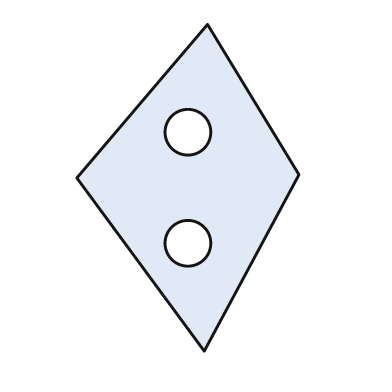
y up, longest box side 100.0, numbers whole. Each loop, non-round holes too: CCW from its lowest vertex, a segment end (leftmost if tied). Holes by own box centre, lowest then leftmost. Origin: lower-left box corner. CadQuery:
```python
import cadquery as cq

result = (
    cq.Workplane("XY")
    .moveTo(39.0, 0.0)
    .lineTo(68.0, 54.0)
    .lineTo(40.0, 100.0)
    .lineTo(0.0, 53.0)
    .close()
    .moveTo(34.0, 33.0)
    .circle(7.0)
    .moveTo(34.0, 67.0)
    .circle(7.0)
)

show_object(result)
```